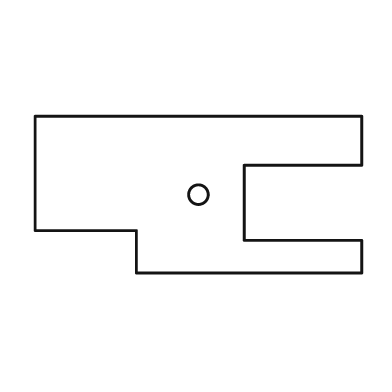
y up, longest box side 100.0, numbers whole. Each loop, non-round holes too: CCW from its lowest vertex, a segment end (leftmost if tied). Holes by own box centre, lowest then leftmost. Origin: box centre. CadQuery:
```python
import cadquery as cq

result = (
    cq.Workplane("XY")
    .moveTo(-19.0, -24.0)
    .lineTo(50.0, -24.0)
    .lineTo(50.0, -14.0)
    .lineTo(14.0, -14.0)
    .lineTo(14.0, 9.0)
    .lineTo(50.0, 9.0)
    .lineTo(50.0, 24.0)
    .lineTo(-50.0, 24.0)
    .lineTo(-50.0, -11.0)
    .lineTo(-19.0, -11.0)
    .close()
    .moveTo(0.0, 0.0)
    .circle(3.0)
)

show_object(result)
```